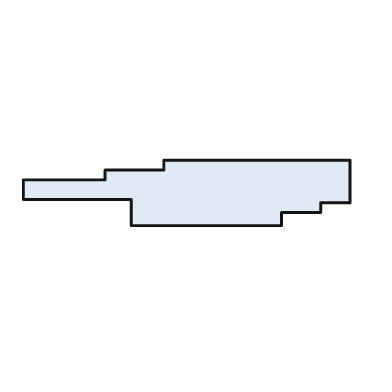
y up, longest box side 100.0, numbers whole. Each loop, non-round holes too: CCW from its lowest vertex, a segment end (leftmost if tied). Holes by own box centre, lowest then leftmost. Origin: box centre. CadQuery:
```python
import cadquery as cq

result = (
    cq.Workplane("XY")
    .moveTo(-17.0, -10.0)
    .lineTo(29.0, -10.0)
    .lineTo(29.0, -6.0)
    .lineTo(41.0, -6.0)
    .lineTo(41.0, -3.0)
    .lineTo(50.0, -3.0)
    .lineTo(50.0, 10.0)
    .lineTo(-7.0, 10.0)
    .lineTo(-7.0, 7.0)
    .lineTo(-25.0, 7.0)
    .lineTo(-25.0, 4.0)
    .lineTo(-50.0, 4.0)
    .lineTo(-50.0, -2.0)
    .lineTo(-17.0, -2.0)
    .close()
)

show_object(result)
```